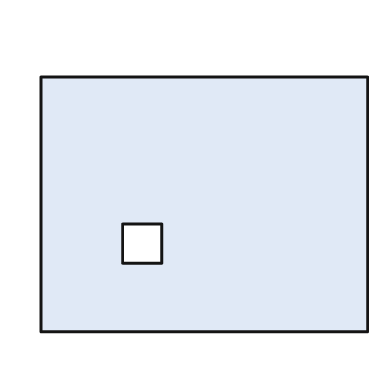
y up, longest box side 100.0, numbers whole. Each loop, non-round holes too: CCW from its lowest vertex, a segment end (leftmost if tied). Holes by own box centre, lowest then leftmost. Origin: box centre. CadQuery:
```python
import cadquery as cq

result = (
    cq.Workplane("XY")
    .moveTo(-50.0, -39.0)
    .lineTo(50.0, -39.0)
    .lineTo(50.0, 39.0)
    .lineTo(-50.0, 39.0)
    .close()
    .moveTo(-25.0, -18.0)
    .lineTo(-13.0, -18.0)
    .lineTo(-13.0, -6.0)
    .lineTo(-25.0, -6.0)
    .close()
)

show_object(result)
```